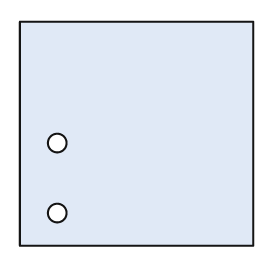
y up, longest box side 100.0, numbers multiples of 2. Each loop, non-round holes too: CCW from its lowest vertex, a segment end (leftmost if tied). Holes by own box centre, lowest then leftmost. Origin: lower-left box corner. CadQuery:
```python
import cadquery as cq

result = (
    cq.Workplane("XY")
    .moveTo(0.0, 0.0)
    .lineTo(100.0, 0.0)
    .lineTo(100.0, 96.0)
    .lineTo(0.0, 96.0)
    .close()
    .moveTo(16.0, 14.0)
    .circle(4.0)
    .moveTo(16.0, 44.0)
    .circle(4.0)
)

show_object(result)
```